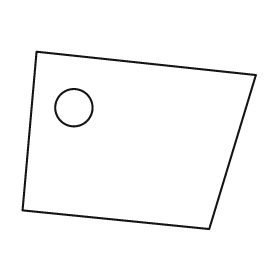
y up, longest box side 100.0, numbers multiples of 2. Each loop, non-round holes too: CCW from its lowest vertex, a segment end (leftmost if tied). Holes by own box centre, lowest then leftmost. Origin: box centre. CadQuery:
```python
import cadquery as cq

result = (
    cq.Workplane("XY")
    .moveTo(30.0, -38.0)
    .lineTo(50.0, 28.0)
    .lineTo(-44.0, 38.0)
    .lineTo(-50.0, -30.0)
    .close()
    .moveTo(-28.0, 14.0)
    .circle(8.0)
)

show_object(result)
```